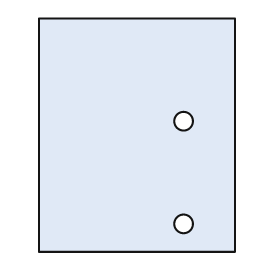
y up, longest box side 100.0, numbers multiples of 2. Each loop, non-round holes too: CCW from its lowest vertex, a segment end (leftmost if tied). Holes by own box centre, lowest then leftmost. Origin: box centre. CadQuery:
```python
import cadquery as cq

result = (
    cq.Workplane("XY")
    .moveTo(-42.0, -50.0)
    .lineTo(42.0, -50.0)
    .lineTo(42.0, 50.0)
    .lineTo(-42.0, 50.0)
    .close()
    .moveTo(20.0, -38.0)
    .circle(4.0)
    .moveTo(20.0, 6.0)
    .circle(4.0)
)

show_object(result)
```